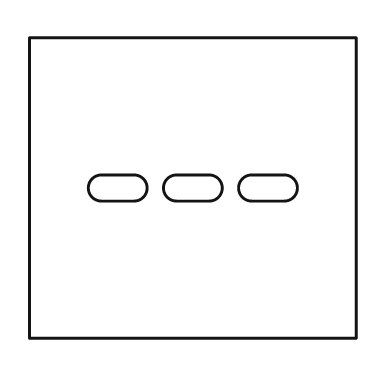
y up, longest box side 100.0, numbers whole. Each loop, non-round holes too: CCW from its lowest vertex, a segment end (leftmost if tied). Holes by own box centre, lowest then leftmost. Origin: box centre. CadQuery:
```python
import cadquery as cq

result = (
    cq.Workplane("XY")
    .moveTo(-50.0, -46.0)
    .lineTo(50.0, -46.0)
    .lineTo(50.0, 46.0)
    .lineTo(-50.0, 46.0)
    .close()
    .moveTo(-28.0, -4.0)
    .lineTo(-18.0, -4.0)
    .threePointArc((-14.0, 0.0), (-18.0, 4.0))
    .lineTo(-28.0, 4.0)
    .threePointArc((-32.0, 0.0), (-28.0, -4.0))
    .close()
    .moveTo(-5.0, -4.0)
    .lineTo(5.0, -4.0)
    .threePointArc((9.0, 0.0), (5.0, 4.0))
    .lineTo(-5.0, 4.0)
    .threePointArc((-9.0, 0.0), (-5.0, -4.0))
    .close()
    .moveTo(18.0, -4.0)
    .lineTo(28.0, -4.0)
    .threePointArc((32.0, 0.0), (28.0, 4.0))
    .lineTo(18.0, 4.0)
    .threePointArc((14.0, 0.0), (18.0, -4.0))
    .close()
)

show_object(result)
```